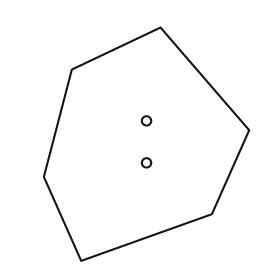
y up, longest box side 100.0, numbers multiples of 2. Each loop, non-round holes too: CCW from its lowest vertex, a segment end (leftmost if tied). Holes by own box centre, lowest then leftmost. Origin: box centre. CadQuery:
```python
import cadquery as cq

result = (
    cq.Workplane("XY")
    .moveTo(-28.0, -50.0)
    .lineTo(28.0, -30.0)
    .lineTo(44.0, 6.0)
    .lineTo(6.0, 50.0)
    .lineTo(-32.0, 32.0)
    .lineTo(-44.0, -14.0)
    .close()
    .moveTo(0.0, -8.0)
    .circle(2.0)
    .moveTo(0.0, 10.0)
    .circle(2.0)
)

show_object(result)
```